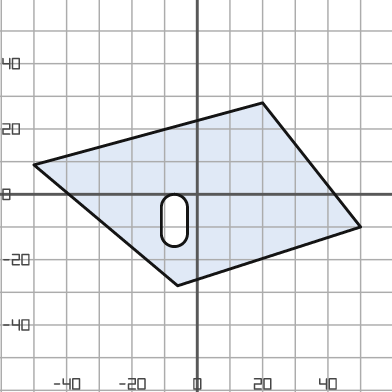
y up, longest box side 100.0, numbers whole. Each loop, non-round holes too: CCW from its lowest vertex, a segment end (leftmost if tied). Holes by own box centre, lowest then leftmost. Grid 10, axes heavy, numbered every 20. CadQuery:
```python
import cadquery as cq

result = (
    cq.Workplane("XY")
    .moveTo(-6.0, -28.0)
    .lineTo(50.0, -10.0)
    .lineTo(20.0, 28.0)
    .lineTo(-50.0, 9.0)
    .close()
    .moveTo(-11.0, -12.0)
    .threePointArc((-7.0, -16.0), (-3.0, -12.0))
    .lineTo(-3.0, -4.0)
    .threePointArc((-7.0, 0.0), (-11.0, -4.0))
    .close()
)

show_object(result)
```